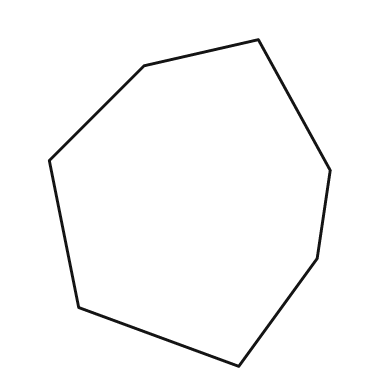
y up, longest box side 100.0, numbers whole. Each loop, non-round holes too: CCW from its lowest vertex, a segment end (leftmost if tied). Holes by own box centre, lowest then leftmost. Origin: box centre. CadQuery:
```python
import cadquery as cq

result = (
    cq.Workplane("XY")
    .moveTo(15.0, -50.0)
    .lineTo(39.0, -17.0)
    .lineTo(43.0, 10.0)
    .lineTo(21.0, 50.0)
    .lineTo(-14.0, 42.0)
    .lineTo(-43.0, 13.0)
    .lineTo(-34.0, -32.0)
    .close()
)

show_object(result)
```